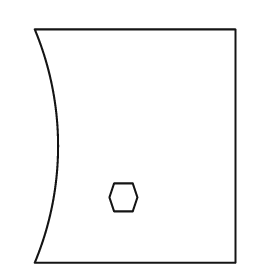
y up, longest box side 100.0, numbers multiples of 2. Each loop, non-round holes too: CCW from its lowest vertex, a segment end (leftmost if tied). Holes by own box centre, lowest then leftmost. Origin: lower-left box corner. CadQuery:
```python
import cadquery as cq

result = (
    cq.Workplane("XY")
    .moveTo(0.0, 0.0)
    .lineTo(86.0, 0.0)
    .lineTo(86.0, 100.0)
    .lineTo(0.0, 100.0)
    .threePointArc((10.0, 50.0), (0.0, 0.0))
    .close()
    .moveTo(34.0, 22.0)
    .lineTo(42.0, 22.0)
    .lineTo(44.0, 28.0)
    .lineTo(42.0, 34.0)
    .lineTo(34.0, 34.0)
    .lineTo(32.0, 28.0)
    .close()
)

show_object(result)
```